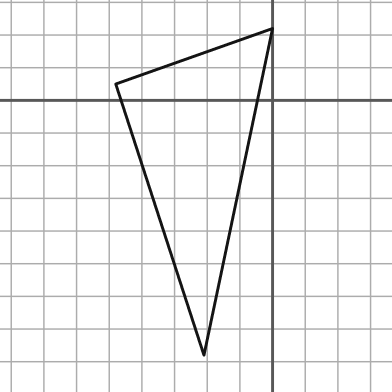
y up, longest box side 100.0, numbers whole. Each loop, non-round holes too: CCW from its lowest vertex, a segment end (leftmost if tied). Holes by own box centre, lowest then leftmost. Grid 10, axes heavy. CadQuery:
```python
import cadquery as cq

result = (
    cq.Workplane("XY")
    .moveTo(-21.0, -78.0)
    .lineTo(0.0, 22.0)
    .lineTo(-48.0, 5.0)
    .close()
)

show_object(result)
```